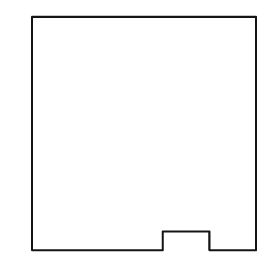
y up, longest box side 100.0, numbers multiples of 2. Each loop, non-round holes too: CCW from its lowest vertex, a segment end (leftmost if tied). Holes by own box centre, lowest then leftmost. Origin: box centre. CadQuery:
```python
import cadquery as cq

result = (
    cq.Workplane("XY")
    .moveTo(-48.0, -50.0)
    .lineTo(8.0, -50.0)
    .lineTo(8.0, -42.0)
    .lineTo(28.0, -42.0)
    .lineTo(28.0, -50.0)
    .lineTo(48.0, -50.0)
    .lineTo(48.0, 50.0)
    .lineTo(-48.0, 50.0)
    .close()
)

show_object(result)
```